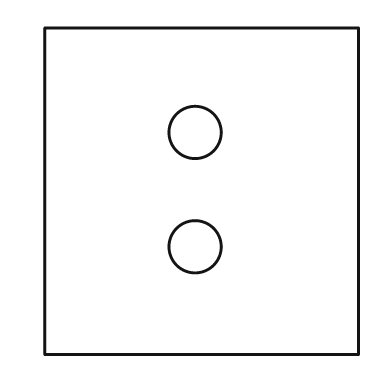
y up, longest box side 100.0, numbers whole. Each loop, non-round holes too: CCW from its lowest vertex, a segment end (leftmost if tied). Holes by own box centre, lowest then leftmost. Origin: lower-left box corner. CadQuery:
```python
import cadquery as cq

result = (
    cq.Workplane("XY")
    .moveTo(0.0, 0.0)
    .lineTo(96.0, 0.0)
    .lineTo(96.0, 100.0)
    .lineTo(0.0, 100.0)
    .close()
    .moveTo(46.0, 33.0)
    .circle(8.0)
    .moveTo(46.0, 68.0)
    .circle(8.0)
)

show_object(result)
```